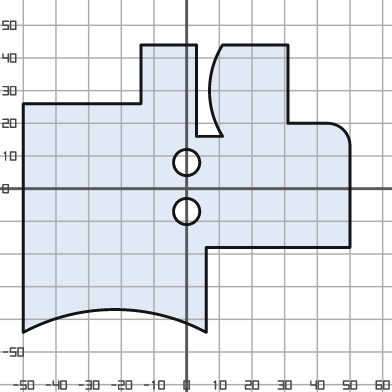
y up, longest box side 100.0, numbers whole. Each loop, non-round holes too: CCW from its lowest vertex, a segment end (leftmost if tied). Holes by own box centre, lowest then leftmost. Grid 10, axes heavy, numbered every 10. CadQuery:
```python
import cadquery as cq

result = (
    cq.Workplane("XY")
    .moveTo(-50.0, -44.0)
    .threePointArc((-22.0, -37.0), (6.0, -44.0))
    .lineTo(6.0, -18.0)
    .lineTo(50.0, -18.0)
    .lineTo(50.0, 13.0)
    .threePointArc((48.0, 18.0), (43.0, 20.0))
    .lineTo(31.0, 20.0)
    .lineTo(31.0, 44.0)
    .lineTo(11.0, 44.0)
    .threePointArc((7.0, 30.0), (11.0, 16.0))
    .lineTo(3.0, 16.0)
    .lineTo(3.0, 44.0)
    .lineTo(-14.0, 44.0)
    .lineTo(-14.0, 26.0)
    .lineTo(-50.0, 26.0)
    .close()
    .moveTo(0.0, -7.0)
    .circle(4.0)
    .moveTo(0.0, 8.0)
    .circle(4.0)
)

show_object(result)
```